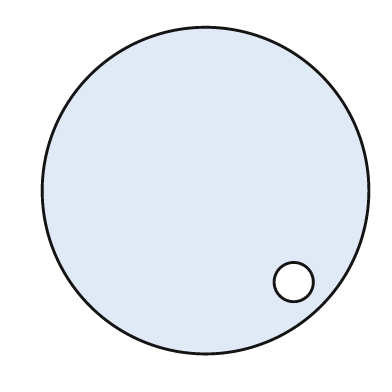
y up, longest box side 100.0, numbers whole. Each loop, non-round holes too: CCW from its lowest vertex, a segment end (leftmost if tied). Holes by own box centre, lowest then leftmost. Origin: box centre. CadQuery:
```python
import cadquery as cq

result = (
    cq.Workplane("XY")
    .moveTo(0.0, 0.0)
    .circle(50.0)
    .moveTo(27.0, -28.0)
    .circle(6.0)
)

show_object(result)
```